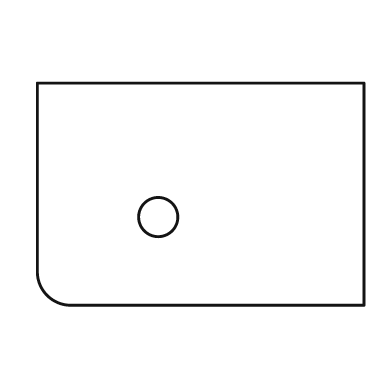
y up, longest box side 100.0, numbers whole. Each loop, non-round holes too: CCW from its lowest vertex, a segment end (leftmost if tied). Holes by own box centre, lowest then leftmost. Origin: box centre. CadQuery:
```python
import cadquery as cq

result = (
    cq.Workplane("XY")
    .moveTo(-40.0, -34.0)
    .lineTo(50.0, -34.0)
    .lineTo(50.0, 34.0)
    .lineTo(-50.0, 34.0)
    .lineTo(-50.0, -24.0)
    .threePointArc((-47.0, -31.0), (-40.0, -34.0))
    .close()
    .moveTo(-13.0, -7.0)
    .circle(6.0)
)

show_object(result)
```